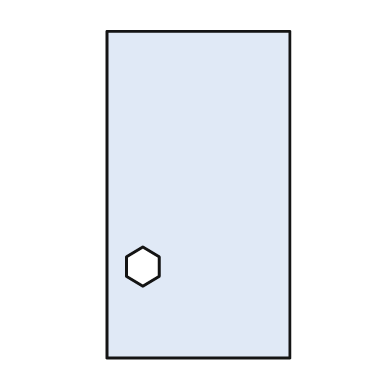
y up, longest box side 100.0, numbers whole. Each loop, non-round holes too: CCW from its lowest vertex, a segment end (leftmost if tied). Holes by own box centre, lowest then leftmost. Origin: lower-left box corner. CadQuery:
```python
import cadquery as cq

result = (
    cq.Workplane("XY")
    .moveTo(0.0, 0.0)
    .lineTo(56.0, 0.0)
    .lineTo(56.0, 100.0)
    .lineTo(0.0, 100.0)
    .close()
    .moveTo(11.0, 22.0)
    .lineTo(16.0, 25.0)
    .lineTo(16.0, 31.0)
    .lineTo(11.0, 34.0)
    .lineTo(6.0, 31.0)
    .lineTo(6.0, 25.0)
    .close()
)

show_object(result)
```